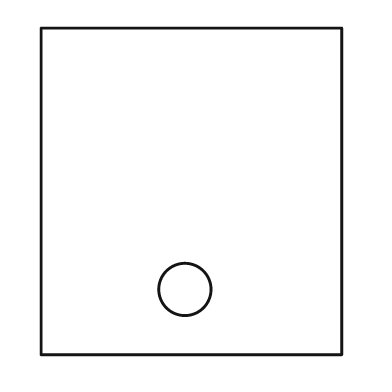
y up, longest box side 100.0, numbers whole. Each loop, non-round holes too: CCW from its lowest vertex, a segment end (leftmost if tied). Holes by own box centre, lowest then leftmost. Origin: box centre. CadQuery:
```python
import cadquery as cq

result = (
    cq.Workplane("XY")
    .moveTo(-46.0, -50.0)
    .lineTo(46.0, -50.0)
    .lineTo(46.0, 50.0)
    .lineTo(-46.0, 50.0)
    .close()
    .moveTo(-2.0, -30.0)
    .circle(8.0)
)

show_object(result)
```